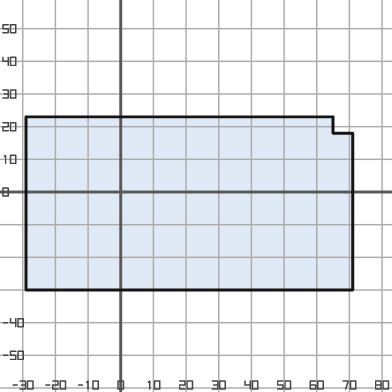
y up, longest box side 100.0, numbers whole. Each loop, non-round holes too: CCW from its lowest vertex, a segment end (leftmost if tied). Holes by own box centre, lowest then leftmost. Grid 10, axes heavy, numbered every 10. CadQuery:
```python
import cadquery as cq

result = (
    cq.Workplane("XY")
    .moveTo(-29.0, -30.0)
    .lineTo(71.0, -30.0)
    .lineTo(71.0, 18.0)
    .lineTo(65.0, 18.0)
    .lineTo(65.0, 23.0)
    .lineTo(-29.0, 23.0)
    .close()
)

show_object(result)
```